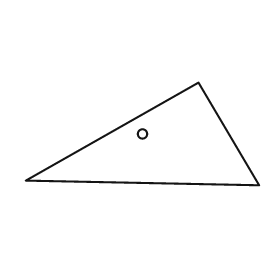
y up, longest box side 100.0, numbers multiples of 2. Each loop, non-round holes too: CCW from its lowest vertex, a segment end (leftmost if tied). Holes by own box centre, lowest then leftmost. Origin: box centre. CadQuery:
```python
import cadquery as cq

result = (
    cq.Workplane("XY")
    .moveTo(50.0, -22.0)
    .lineTo(24.0, 22.0)
    .lineTo(-50.0, -20.0)
    .close()
    .moveTo(0.0, 0.0)
    .circle(2.0)
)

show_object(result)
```